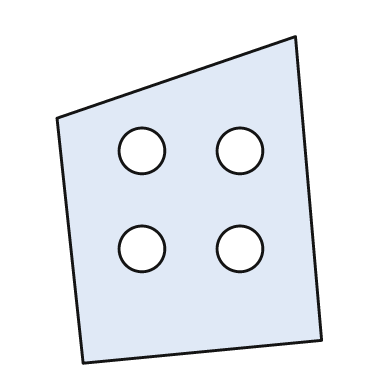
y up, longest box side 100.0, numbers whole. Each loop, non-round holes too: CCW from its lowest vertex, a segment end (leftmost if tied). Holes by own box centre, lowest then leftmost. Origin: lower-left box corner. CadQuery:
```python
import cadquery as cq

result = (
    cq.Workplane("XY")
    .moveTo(8.0, 0.0)
    .lineTo(81.0, 7.0)
    .lineTo(73.0, 100.0)
    .lineTo(0.0, 75.0)
    .close()
    .moveTo(26.0, 35.0)
    .circle(7.0)
    .moveTo(56.0, 35.0)
    .circle(7.0)
    .moveTo(26.0, 65.0)
    .circle(7.0)
    .moveTo(56.0, 65.0)
    .circle(7.0)
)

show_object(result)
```